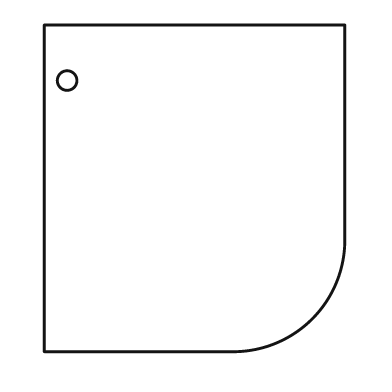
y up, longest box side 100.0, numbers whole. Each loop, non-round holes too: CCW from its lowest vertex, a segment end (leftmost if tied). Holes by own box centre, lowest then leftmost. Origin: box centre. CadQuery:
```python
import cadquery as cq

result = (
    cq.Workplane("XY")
    .moveTo(-46.0, -50.0)
    .lineTo(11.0, -50.0)
    .threePointArc((36.0, -40.0), (46.0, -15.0))
    .lineTo(46.0, 50.0)
    .lineTo(-46.0, 50.0)
    .close()
    .moveTo(-39.0, 33.0)
    .circle(3.0)
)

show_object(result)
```